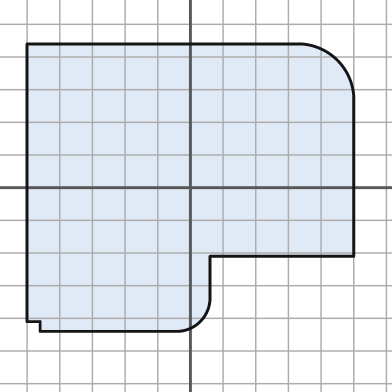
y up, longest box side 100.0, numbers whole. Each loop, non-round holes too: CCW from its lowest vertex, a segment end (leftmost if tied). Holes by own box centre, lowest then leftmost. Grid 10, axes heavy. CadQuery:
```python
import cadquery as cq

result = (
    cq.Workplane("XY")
    .moveTo(-46.0, -44.0)
    .lineTo(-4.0, -44.0)
    .threePointArc((3.0, -41.0), (6.0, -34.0))
    .lineTo(6.0, -21.0)
    .lineTo(50.0, -21.0)
    .lineTo(50.0, 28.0)
    .threePointArc((45.0, 39.0), (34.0, 44.0))
    .lineTo(-50.0, 44.0)
    .lineTo(-50.0, -41.0)
    .lineTo(-46.0, -41.0)
    .close()
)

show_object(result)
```